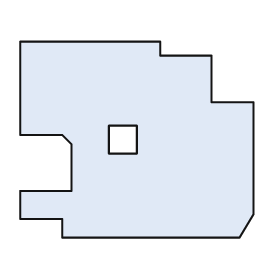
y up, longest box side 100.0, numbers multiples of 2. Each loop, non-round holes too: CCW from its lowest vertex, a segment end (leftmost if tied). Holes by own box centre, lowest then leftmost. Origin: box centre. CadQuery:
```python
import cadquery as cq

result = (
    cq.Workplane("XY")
    .moveTo(-32.0, -42.0)
    .lineTo(44.0, -42.0)
    .lineTo(50.0, -32.0)
    .lineTo(50.0, 16.0)
    .lineTo(32.0, 16.0)
    .lineTo(32.0, 36.0)
    .lineTo(10.0, 36.0)
    .lineTo(10.0, 42.0)
    .lineTo(-50.0, 42.0)
    .lineTo(-50.0, 2.0)
    .lineTo(-32.0, 2.0)
    .lineTo(-28.0, -2.0)
    .lineTo(-28.0, -22.0)
    .lineTo(-50.0, -22.0)
    .lineTo(-50.0, -34.0)
    .lineTo(-32.0, -34.0)
    .close()
    .moveTo(-12.0, -6.0)
    .lineTo(0.0, -6.0)
    .lineTo(0.0, 6.0)
    .lineTo(-12.0, 6.0)
    .close()
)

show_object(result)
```